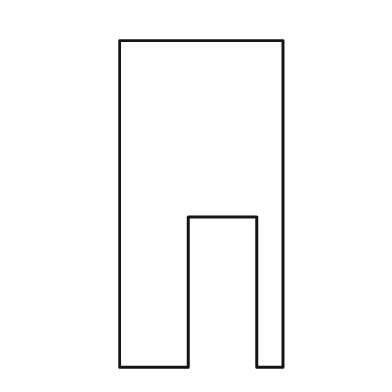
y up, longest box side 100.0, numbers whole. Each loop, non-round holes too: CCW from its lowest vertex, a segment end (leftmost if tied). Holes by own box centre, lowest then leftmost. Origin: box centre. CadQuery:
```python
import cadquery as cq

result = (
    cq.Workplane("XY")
    .moveTo(-25.0, -50.0)
    .lineTo(-4.0, -50.0)
    .lineTo(-4.0, -4.0)
    .lineTo(17.0, -4.0)
    .lineTo(17.0, -50.0)
    .lineTo(25.0, -50.0)
    .lineTo(25.0, 50.0)
    .lineTo(-25.0, 50.0)
    .close()
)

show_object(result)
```